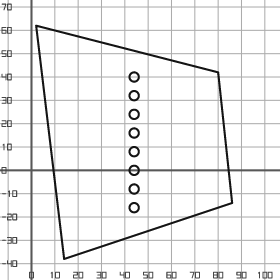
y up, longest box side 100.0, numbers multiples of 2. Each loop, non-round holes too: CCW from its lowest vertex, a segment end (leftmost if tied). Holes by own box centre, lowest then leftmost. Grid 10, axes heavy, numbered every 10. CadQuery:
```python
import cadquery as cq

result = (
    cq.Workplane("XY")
    .moveTo(14.0, -38.0)
    .lineTo(86.0, -14.0)
    .lineTo(80.0, 42.0)
    .lineTo(2.0, 62.0)
    .close()
    .moveTo(44.0, -16.0)
    .circle(2.0)
    .moveTo(44.0, -8.0)
    .circle(2.0)
    .moveTo(44.0, 0.0)
    .circle(2.0)
    .moveTo(44.0, 8.0)
    .circle(2.0)
    .moveTo(44.0, 16.0)
    .circle(2.0)
    .moveTo(44.0, 24.0)
    .circle(2.0)
    .moveTo(44.0, 32.0)
    .circle(2.0)
    .moveTo(44.0, 40.0)
    .circle(2.0)
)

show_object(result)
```